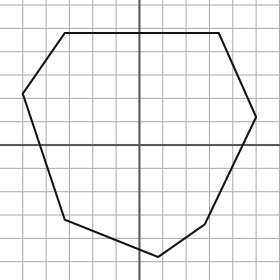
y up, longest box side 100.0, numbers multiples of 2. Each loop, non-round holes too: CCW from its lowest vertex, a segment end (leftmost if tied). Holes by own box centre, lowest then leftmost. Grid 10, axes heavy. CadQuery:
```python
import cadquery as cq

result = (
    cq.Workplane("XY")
    .moveTo(8.0, -48.0)
    .lineTo(28.0, -34.0)
    .lineTo(50.0, 12.0)
    .lineTo(34.0, 48.0)
    .lineTo(-32.0, 48.0)
    .lineTo(-50.0, 22.0)
    .lineTo(-32.0, -32.0)
    .close()
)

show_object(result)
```